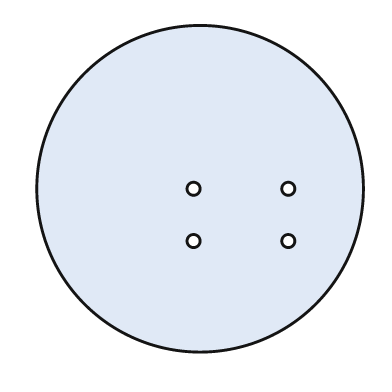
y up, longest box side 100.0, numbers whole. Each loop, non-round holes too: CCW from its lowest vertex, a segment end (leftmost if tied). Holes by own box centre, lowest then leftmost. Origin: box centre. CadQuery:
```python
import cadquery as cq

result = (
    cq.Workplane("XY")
    .moveTo(0.0, 0.0)
    .circle(50.0)
    .moveTo(-2.0, -16.0)
    .circle(2.0)
    .moveTo(27.0, -16.0)
    .circle(2.0)
    .moveTo(-2.0, 0.0)
    .circle(2.0)
    .moveTo(27.0, 0.0)
    .circle(2.0)
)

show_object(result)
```